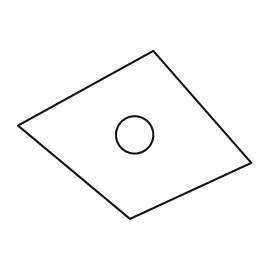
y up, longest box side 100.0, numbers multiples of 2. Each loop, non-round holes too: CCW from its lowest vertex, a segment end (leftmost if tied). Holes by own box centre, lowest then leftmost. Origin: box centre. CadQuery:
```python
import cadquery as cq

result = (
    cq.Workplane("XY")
    .moveTo(-2.0, -36.0)
    .lineTo(50.0, -12.0)
    .lineTo(8.0, 36.0)
    .lineTo(-50.0, 4.0)
    .close()
    .moveTo(0.0, 0.0)
    .circle(8.0)
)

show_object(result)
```